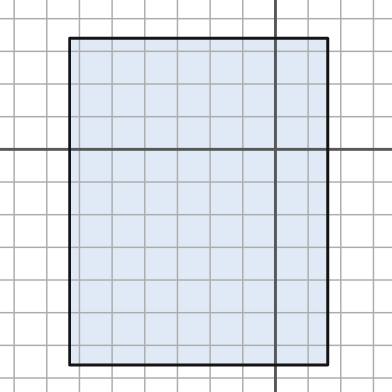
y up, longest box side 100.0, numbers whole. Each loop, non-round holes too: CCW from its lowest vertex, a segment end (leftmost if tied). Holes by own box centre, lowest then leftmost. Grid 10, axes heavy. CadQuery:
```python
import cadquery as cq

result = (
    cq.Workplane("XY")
    .moveTo(-63.0, -66.0)
    .lineTo(16.0, -66.0)
    .lineTo(16.0, 34.0)
    .lineTo(-63.0, 34.0)
    .close()
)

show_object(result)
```